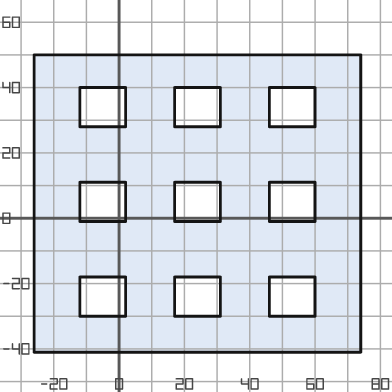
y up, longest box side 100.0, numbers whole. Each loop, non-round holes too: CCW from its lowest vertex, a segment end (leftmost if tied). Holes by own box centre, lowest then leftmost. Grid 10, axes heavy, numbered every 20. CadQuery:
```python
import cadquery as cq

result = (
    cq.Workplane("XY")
    .moveTo(-26.0, -41.0)
    .lineTo(74.0, -41.0)
    .lineTo(74.0, 50.0)
    .lineTo(-26.0, 50.0)
    .close()
    .moveTo(-12.0, -30.0)
    .lineTo(2.0, -30.0)
    .lineTo(2.0, -18.0)
    .lineTo(-12.0, -18.0)
    .close()
    .moveTo(17.0, -30.0)
    .lineTo(31.0, -30.0)
    .lineTo(31.0, -18.0)
    .lineTo(17.0, -18.0)
    .close()
    .moveTo(46.0, -30.0)
    .lineTo(60.0, -30.0)
    .lineTo(60.0, -18.0)
    .lineTo(46.0, -18.0)
    .close()
    .moveTo(-12.0, -1.0)
    .lineTo(2.0, -1.0)
    .lineTo(2.0, 11.0)
    .lineTo(-12.0, 11.0)
    .close()
    .moveTo(17.0, -1.0)
    .lineTo(31.0, -1.0)
    .lineTo(31.0, 11.0)
    .lineTo(17.0, 11.0)
    .close()
    .moveTo(46.0, -1.0)
    .lineTo(60.0, -1.0)
    .lineTo(60.0, 11.0)
    .lineTo(46.0, 11.0)
    .close()
    .moveTo(-12.0, 28.0)
    .lineTo(2.0, 28.0)
    .lineTo(2.0, 40.0)
    .lineTo(-12.0, 40.0)
    .close()
    .moveTo(17.0, 28.0)
    .lineTo(31.0, 28.0)
    .lineTo(31.0, 40.0)
    .lineTo(17.0, 40.0)
    .close()
    .moveTo(46.0, 28.0)
    .lineTo(60.0, 28.0)
    .lineTo(60.0, 40.0)
    .lineTo(46.0, 40.0)
    .close()
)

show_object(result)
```